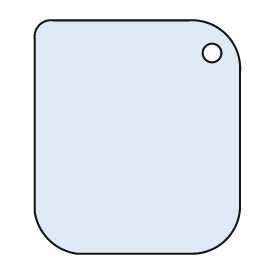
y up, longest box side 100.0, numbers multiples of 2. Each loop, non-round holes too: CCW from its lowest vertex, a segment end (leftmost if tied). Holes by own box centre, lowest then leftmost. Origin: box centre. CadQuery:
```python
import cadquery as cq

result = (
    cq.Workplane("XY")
    .moveTo(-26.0, -50.0)
    .lineTo(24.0, -50.0)
    .threePointArc((38.0, -44.0), (44.0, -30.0))
    .lineTo(44.0, 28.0)
    .threePointArc((38.0, 44.0), (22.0, 50.0))
    .lineTo(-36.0, 50.0)
    .threePointArc((-42.0, 48.0), (-44.0, 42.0))
    .lineTo(-44.0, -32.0)
    .threePointArc((-38.0, -44.0), (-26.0, -50.0))
    .close()
    .moveTo(32.0, 36.0)
    .circle(4.0)
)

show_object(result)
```